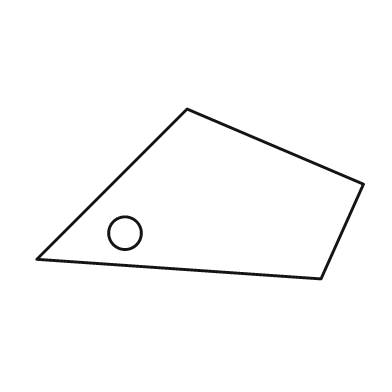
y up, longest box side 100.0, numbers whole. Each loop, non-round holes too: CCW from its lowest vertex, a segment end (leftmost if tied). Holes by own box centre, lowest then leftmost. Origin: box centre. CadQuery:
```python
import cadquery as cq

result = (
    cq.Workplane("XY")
    .moveTo(37.0, -26.0)
    .lineTo(50.0, 3.0)
    .lineTo(-4.0, 26.0)
    .lineTo(-50.0, -20.0)
    .close()
    .moveTo(-23.0, -12.0)
    .circle(5.0)
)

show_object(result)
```